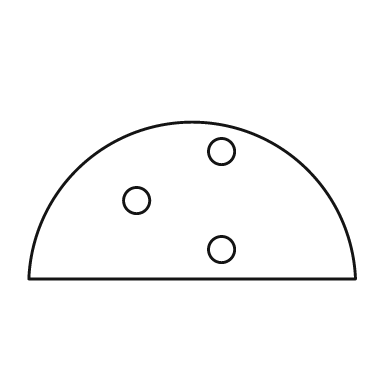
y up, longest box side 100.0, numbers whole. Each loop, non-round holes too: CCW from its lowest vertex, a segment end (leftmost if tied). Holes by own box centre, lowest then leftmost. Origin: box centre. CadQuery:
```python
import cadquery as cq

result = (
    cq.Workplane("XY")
    .moveTo(-50.0, -24.0)
    .lineTo(50.0, -24.0)
    .threePointArc((0.0, 24.0), (-50.0, -24.0))
    .close()
    .moveTo(9.0, -15.0)
    .circle(4.0)
    .moveTo(-17.0, 0.0)
    .circle(4.0)
    .moveTo(9.0, 15.0)
    .circle(4.0)
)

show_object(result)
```